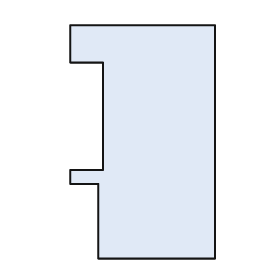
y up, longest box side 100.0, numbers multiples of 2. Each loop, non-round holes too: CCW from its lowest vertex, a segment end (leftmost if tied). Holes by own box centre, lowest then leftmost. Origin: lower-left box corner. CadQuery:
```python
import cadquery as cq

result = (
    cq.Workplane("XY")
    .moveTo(12.0, 0.0)
    .lineTo(62.0, 0.0)
    .lineTo(62.0, 100.0)
    .lineTo(0.0, 100.0)
    .lineTo(0.0, 84.0)
    .lineTo(14.0, 84.0)
    .lineTo(14.0, 38.0)
    .lineTo(0.0, 38.0)
    .lineTo(0.0, 32.0)
    .lineTo(12.0, 32.0)
    .close()
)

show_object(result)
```